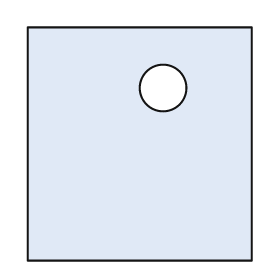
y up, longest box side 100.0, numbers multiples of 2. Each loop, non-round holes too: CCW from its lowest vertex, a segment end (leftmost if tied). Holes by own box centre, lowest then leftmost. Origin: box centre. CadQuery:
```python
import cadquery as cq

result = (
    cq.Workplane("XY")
    .moveTo(-48.0, -50.0)
    .lineTo(48.0, -50.0)
    .lineTo(48.0, 50.0)
    .lineTo(-48.0, 50.0)
    .close()
    .moveTo(10.0, 24.0)
    .circle(10.0)
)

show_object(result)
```